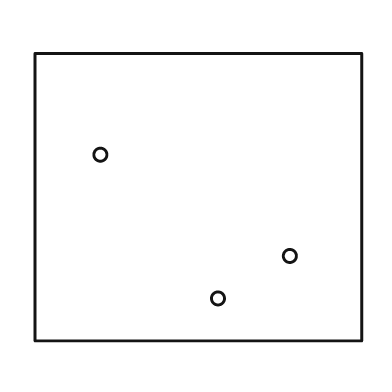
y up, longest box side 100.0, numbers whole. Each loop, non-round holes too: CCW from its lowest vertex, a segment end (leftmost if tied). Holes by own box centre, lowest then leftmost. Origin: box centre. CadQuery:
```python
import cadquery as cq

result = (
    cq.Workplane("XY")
    .moveTo(-50.0, -44.0)
    .lineTo(50.0, -44.0)
    .lineTo(50.0, 44.0)
    .lineTo(-50.0, 44.0)
    .close()
    .moveTo(6.0, -31.0)
    .circle(2.0)
    .moveTo(28.0, -18.0)
    .circle(2.0)
    .moveTo(-30.0, 13.0)
    .circle(2.0)
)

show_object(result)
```